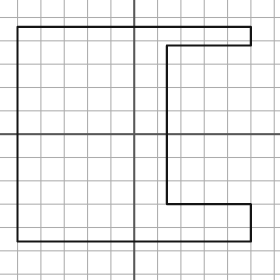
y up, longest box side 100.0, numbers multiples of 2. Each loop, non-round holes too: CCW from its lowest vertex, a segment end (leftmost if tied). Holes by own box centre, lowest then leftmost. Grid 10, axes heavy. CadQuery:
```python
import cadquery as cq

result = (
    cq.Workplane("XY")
    .moveTo(-50.0, -46.0)
    .lineTo(50.0, -46.0)
    .lineTo(50.0, -30.0)
    .lineTo(14.0, -30.0)
    .lineTo(14.0, 38.0)
    .lineTo(50.0, 38.0)
    .lineTo(50.0, 46.0)
    .lineTo(-50.0, 46.0)
    .close()
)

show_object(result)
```